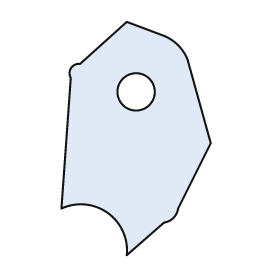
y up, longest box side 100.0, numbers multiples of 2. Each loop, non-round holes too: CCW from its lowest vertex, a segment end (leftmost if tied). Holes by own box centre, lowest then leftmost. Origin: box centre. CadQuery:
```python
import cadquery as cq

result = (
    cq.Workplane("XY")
    .moveTo(-4.0, -50.0)
    .lineTo(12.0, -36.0)
    .threePointArc((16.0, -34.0), (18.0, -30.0))
    .lineTo(32.0, -2.0)
    .lineTo(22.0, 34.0)
    .threePointArc((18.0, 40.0), (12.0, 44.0))
    .lineTo(-4.0, 50.0)
    .lineTo(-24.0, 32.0)
    .threePointArc((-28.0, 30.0), (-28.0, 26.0))
    .lineTo(-32.0, -30.0)
    .threePointArc((-12.0, -32.0), (-4.0, -50.0))
    .close()
    .moveTo(0.0, 20.0)
    .circle(8.0)
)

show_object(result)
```